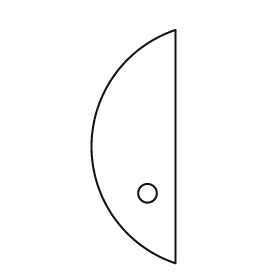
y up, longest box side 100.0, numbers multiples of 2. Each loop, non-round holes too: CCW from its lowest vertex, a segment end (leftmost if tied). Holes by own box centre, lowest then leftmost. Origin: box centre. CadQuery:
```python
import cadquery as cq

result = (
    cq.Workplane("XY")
    .moveTo(18.0, -50.0)
    .lineTo(18.0, 50.0)
    .threePointArc((-18.0, 0.0), (18.0, -50.0))
    .close()
    .moveTo(6.0, -20.0)
    .circle(4.0)
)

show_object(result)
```